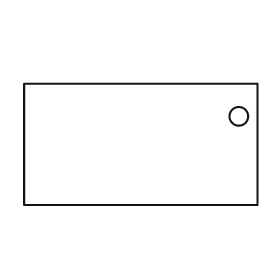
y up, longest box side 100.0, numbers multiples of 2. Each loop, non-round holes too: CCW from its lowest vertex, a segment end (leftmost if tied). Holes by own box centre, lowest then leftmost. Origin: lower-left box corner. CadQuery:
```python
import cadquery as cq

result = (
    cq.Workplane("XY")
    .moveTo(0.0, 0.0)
    .lineTo(100.0, 0.0)
    .lineTo(100.0, 52.0)
    .lineTo(0.0, 52.0)
    .close()
    .moveTo(92.0, 38.0)
    .circle(4.0)
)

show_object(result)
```